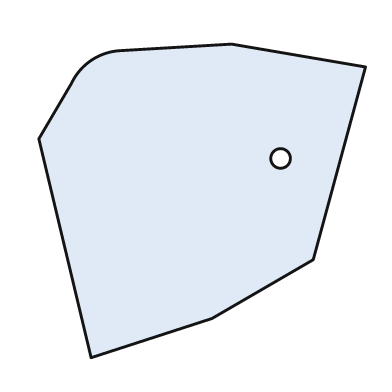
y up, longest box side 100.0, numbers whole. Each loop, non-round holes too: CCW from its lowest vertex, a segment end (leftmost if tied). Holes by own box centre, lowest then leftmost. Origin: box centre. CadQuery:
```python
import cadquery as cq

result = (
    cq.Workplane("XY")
    .moveTo(-34.0, -48.0)
    .lineTo(3.0, -36.0)
    .lineTo(34.0, -18.0)
    .lineTo(50.0, 41.0)
    .lineTo(9.0, 48.0)
    .lineTo(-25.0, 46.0)
    .threePointArc((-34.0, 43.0), (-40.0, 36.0))
    .lineTo(-50.0, 19.0)
    .close()
    .moveTo(24.0, 13.0)
    .circle(3.0)
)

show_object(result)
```